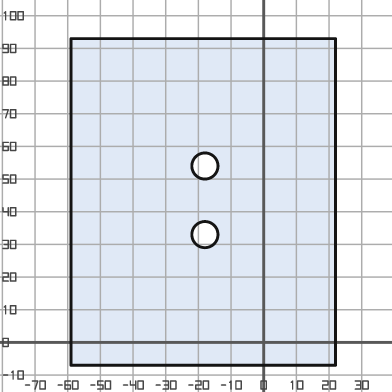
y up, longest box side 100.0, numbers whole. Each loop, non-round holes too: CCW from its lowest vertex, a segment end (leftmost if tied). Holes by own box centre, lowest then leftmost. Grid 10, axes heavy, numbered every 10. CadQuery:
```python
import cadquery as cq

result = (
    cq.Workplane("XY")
    .moveTo(-59.0, -7.0)
    .lineTo(22.0, -7.0)
    .lineTo(22.0, 93.0)
    .lineTo(-59.0, 93.0)
    .close()
    .moveTo(-18.0, 33.0)
    .circle(4.0)
    .moveTo(-18.0, 54.0)
    .circle(4.0)
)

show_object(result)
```